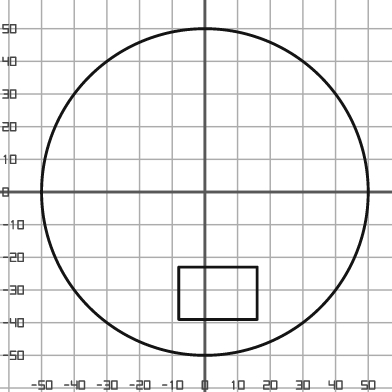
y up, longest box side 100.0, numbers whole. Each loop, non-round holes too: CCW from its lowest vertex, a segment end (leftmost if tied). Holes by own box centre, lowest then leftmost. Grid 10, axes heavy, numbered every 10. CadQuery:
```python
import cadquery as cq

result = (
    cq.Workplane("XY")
    .moveTo(0.0, 0.0)
    .circle(50.0)
    .moveTo(-8.0, -39.0)
    .lineTo(16.0, -39.0)
    .lineTo(16.0, -23.0)
    .lineTo(-8.0, -23.0)
    .close()
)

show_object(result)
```